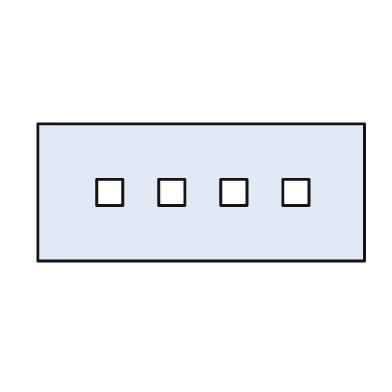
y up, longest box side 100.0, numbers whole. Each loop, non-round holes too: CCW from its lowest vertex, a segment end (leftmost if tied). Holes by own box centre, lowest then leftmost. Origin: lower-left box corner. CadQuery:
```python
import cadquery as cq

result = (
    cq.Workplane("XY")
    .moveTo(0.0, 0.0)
    .lineTo(100.0, 0.0)
    .lineTo(100.0, 42.0)
    .lineTo(0.0, 42.0)
    .close()
    .moveTo(18.0, 17.0)
    .lineTo(26.0, 17.0)
    .lineTo(26.0, 25.0)
    .lineTo(18.0, 25.0)
    .close()
    .moveTo(37.0, 17.0)
    .lineTo(45.0, 17.0)
    .lineTo(45.0, 25.0)
    .lineTo(37.0, 25.0)
    .close()
    .moveTo(56.0, 17.0)
    .lineTo(64.0, 17.0)
    .lineTo(64.0, 25.0)
    .lineTo(56.0, 25.0)
    .close()
    .moveTo(75.0, 17.0)
    .lineTo(83.0, 17.0)
    .lineTo(83.0, 25.0)
    .lineTo(75.0, 25.0)
    .close()
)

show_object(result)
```